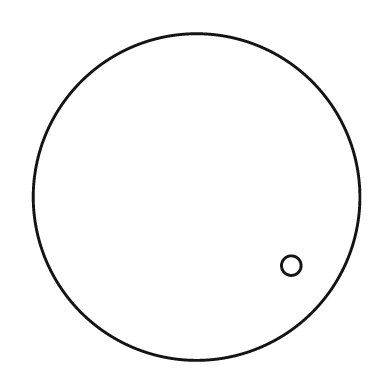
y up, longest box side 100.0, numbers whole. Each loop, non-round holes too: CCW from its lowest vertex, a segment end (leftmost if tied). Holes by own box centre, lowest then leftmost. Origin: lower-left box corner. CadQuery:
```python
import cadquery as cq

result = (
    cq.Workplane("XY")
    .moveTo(50.0, 50.0)
    .circle(50.0)
    .moveTo(79.0, 29.0)
    .circle(3.0)
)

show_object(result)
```